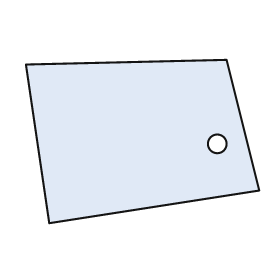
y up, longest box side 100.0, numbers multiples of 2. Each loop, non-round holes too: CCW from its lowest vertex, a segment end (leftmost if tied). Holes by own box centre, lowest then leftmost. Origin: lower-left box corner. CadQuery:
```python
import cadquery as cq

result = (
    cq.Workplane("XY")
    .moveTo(10.0, 0.0)
    .lineTo(100.0, 14.0)
    .lineTo(86.0, 70.0)
    .lineTo(0.0, 68.0)
    .close()
    .moveTo(82.0, 34.0)
    .circle(4.0)
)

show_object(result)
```